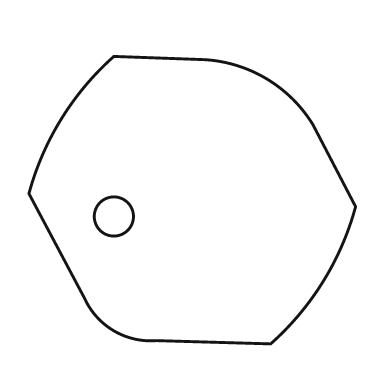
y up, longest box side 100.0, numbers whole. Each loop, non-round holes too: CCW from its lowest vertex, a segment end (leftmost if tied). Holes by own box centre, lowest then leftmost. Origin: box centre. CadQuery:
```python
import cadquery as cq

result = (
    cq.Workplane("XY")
    .moveTo(24.0, -44.0)
    .threePointArc((40.0, -25.0), (50.0, -2.0))
    .lineTo(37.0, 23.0)
    .threePointArc((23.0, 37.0), (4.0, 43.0))
    .lineTo(-24.0, 44.0)
    .threePointArc((-40.0, 25.0), (-50.0, 2.0))
    .lineTo(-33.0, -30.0)
    .threePointArc((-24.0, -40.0), (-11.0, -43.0))
    .close()
    .moveTo(-24.0, -5.0)
    .circle(6.0)
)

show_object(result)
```